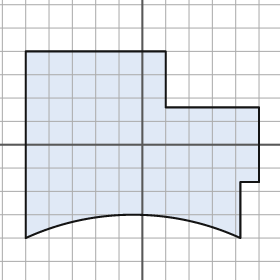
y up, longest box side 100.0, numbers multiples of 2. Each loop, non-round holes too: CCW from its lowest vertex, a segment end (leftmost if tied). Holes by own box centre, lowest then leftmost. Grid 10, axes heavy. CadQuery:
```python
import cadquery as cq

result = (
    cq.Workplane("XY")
    .moveTo(-50.0, -40.0)
    .threePointArc((-4.0, -30.0), (42.0, -40.0))
    .lineTo(42.0, -16.0)
    .lineTo(50.0, -16.0)
    .lineTo(50.0, 16.0)
    .lineTo(10.0, 16.0)
    .lineTo(10.0, 40.0)
    .lineTo(-50.0, 40.0)
    .close()
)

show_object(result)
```